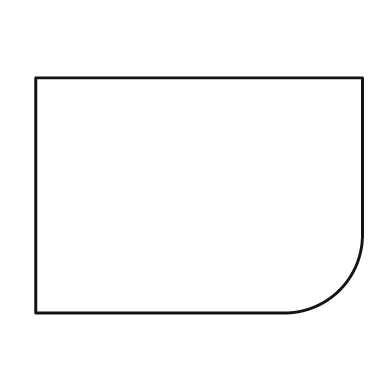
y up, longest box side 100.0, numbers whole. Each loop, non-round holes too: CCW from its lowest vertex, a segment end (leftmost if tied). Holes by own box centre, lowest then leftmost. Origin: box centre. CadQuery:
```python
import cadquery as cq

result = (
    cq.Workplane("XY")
    .moveTo(-50.0, -36.0)
    .lineTo(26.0, -36.0)
    .threePointArc((43.0, -29.0), (50.0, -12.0))
    .lineTo(50.0, 36.0)
    .lineTo(-50.0, 36.0)
    .close()
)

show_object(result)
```